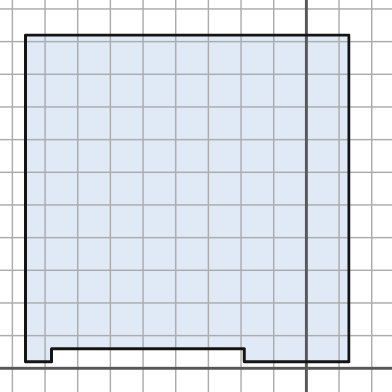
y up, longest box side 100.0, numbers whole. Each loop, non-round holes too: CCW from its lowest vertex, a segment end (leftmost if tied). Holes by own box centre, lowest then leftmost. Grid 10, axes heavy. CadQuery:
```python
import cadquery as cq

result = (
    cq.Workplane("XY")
    .moveTo(-86.0, 2.0)
    .lineTo(-78.0, 2.0)
    .lineTo(-78.0, 6.0)
    .lineTo(-19.0, 6.0)
    .lineTo(-19.0, 2.0)
    .lineTo(13.0, 2.0)
    .lineTo(13.0, 102.0)
    .lineTo(-86.0, 102.0)
    .close()
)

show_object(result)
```